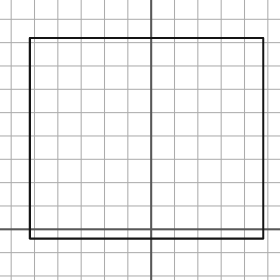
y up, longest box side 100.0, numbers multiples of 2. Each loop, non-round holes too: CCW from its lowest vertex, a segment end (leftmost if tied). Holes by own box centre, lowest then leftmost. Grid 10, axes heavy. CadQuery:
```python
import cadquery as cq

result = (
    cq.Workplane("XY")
    .moveTo(-52.0, -4.0)
    .lineTo(48.0, -4.0)
    .lineTo(48.0, 82.0)
    .lineTo(-52.0, 82.0)
    .close()
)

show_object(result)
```